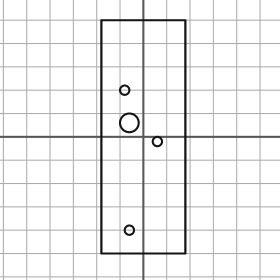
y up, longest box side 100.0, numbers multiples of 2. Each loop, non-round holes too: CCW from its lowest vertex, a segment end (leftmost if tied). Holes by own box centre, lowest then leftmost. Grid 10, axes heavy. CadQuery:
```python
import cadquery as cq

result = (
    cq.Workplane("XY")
    .moveTo(-18.0, -50.0)
    .lineTo(18.0, -50.0)
    .lineTo(18.0, 50.0)
    .lineTo(-18.0, 50.0)
    .close()
    .moveTo(-6.0, -40.0)
    .circle(2.0)
    .moveTo(6.0, -2.0)
    .circle(2.0)
    .moveTo(-6.0, 6.0)
    .circle(4.0)
    .moveTo(-8.0, 20.0)
    .circle(2.0)
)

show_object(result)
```